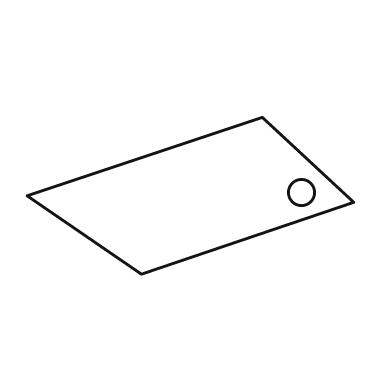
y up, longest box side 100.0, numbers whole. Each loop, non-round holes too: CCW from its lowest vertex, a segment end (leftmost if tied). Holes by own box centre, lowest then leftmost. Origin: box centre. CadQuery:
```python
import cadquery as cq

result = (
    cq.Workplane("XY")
    .moveTo(-15.0, -24.0)
    .lineTo(50.0, -2.0)
    .lineTo(22.0, 24.0)
    .lineTo(-50.0, 0.0)
    .close()
    .moveTo(34.0, 1.0)
    .circle(4.0)
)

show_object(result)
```